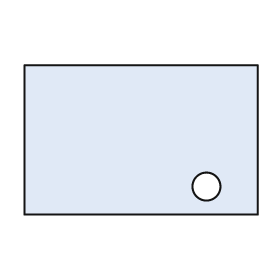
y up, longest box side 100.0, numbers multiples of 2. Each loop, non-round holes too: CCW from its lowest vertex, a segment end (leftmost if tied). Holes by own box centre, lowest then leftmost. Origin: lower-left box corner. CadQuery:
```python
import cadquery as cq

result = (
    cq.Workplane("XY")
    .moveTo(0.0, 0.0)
    .lineTo(100.0, 0.0)
    .lineTo(100.0, 64.0)
    .lineTo(0.0, 64.0)
    .close()
    .moveTo(78.0, 12.0)
    .circle(6.0)
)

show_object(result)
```